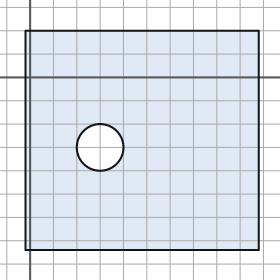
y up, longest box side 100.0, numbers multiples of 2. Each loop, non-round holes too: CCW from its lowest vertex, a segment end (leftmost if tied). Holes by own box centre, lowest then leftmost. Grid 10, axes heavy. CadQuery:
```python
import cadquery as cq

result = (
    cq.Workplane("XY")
    .moveTo(-2.0, -74.0)
    .lineTo(98.0, -74.0)
    .lineTo(98.0, 20.0)
    .lineTo(-2.0, 20.0)
    .close()
    .moveTo(30.0, -30.0)
    .circle(10.0)
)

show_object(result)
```